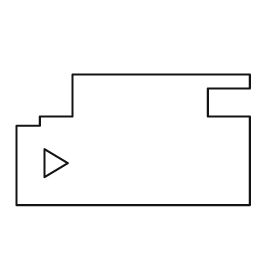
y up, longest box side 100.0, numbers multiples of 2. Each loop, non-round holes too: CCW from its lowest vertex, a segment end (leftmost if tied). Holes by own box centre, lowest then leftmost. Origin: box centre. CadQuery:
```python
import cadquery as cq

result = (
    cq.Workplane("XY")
    .moveTo(-50.0, -28.0)
    .lineTo(50.0, -28.0)
    .lineTo(50.0, 10.0)
    .lineTo(32.0, 10.0)
    .lineTo(32.0, 22.0)
    .lineTo(50.0, 22.0)
    .lineTo(50.0, 28.0)
    .lineTo(-26.0, 28.0)
    .lineTo(-26.0, 10.0)
    .lineTo(-40.0, 10.0)
    .lineTo(-40.0, 6.0)
    .lineTo(-50.0, 6.0)
    .close()
    .moveTo(-38.0, -16.0)
    .lineTo(-28.0, -10.0)
    .lineTo(-38.0, -4.0)
    .close()
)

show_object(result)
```